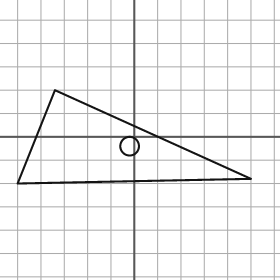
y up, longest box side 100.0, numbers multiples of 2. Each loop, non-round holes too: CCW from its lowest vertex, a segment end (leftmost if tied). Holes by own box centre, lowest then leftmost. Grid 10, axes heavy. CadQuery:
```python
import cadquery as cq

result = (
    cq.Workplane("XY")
    .moveTo(-50.0, -20.0)
    .lineTo(50.0, -18.0)
    .lineTo(-34.0, 20.0)
    .close()
    .moveTo(-2.0, -4.0)
    .circle(4.0)
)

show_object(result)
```